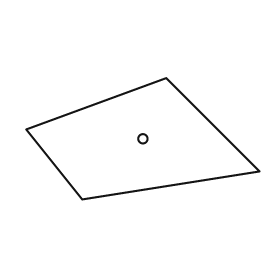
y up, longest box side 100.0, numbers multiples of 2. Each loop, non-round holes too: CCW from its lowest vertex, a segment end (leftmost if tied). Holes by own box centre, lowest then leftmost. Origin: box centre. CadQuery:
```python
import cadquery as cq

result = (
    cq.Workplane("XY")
    .moveTo(-26.0, -26.0)
    .lineTo(50.0, -14.0)
    .lineTo(10.0, 26.0)
    .lineTo(-50.0, 4.0)
    .close()
    .moveTo(0.0, 0.0)
    .circle(2.0)
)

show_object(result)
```